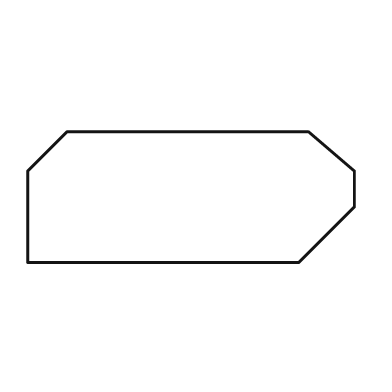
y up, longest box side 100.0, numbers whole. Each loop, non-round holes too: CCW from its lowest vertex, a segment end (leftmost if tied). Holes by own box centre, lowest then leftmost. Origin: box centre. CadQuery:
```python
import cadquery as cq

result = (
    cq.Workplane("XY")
    .moveTo(-50.0, -20.0)
    .lineTo(33.0, -20.0)
    .lineTo(50.0, -3.0)
    .lineTo(50.0, 8.0)
    .lineTo(36.0, 20.0)
    .lineTo(-38.0, 20.0)
    .lineTo(-50.0, 8.0)
    .close()
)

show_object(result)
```